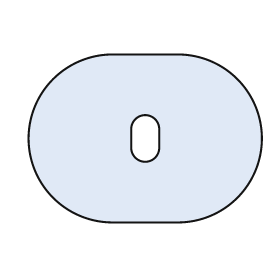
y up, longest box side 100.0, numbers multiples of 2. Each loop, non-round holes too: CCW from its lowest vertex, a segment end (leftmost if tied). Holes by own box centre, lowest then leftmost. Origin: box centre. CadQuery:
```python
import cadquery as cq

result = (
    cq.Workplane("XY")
    .moveTo(-14.0, -36.0)
    .lineTo(14.0, -36.0)
    .threePointArc((50.0, 0.0), (14.0, 36.0))
    .lineTo(-14.0, 36.0)
    .threePointArc((-50.0, 0.0), (-14.0, -36.0))
    .close()
    .moveTo(-6.0, -4.0)
    .threePointArc((0.0, -10.0), (6.0, -4.0))
    .lineTo(6.0, 4.0)
    .threePointArc((0.0, 10.0), (-6.0, 4.0))
    .close()
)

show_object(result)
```